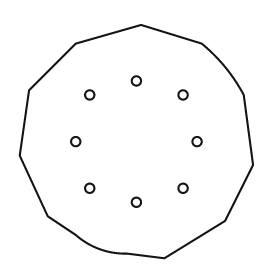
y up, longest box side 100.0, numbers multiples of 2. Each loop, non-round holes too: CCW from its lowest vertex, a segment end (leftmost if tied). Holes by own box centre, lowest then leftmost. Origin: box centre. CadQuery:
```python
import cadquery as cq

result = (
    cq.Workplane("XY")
    .moveTo(12.0, -50.0)
    .lineTo(38.0, -34.0)
    .lineTo(50.0, -10.0)
    .lineTo(46.0, 20.0)
    .threePointArc((38.0, 32.0), (28.0, 42.0))
    .lineTo(2.0, 50.0)
    .lineTo(-26.0, 42.0)
    .lineTo(-46.0, 22.0)
    .lineTo(-50.0, -6.0)
    .lineTo(-38.0, -32.0)
    .lineTo(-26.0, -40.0)
    .threePointArc((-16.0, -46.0), (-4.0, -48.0))
    .close()
    .moveTo(0.0, -26.0)
    .circle(2.0)
    .moveTo(-20.0, -20.0)
    .circle(2.0)
    .moveTo(20.0, -20.0)
    .circle(2.0)
    .moveTo(-26.0, 0.0)
    .circle(2.0)
    .moveTo(26.0, 0.0)
    .circle(2.0)
    .moveTo(-20.0, 20.0)
    .circle(2.0)
    .moveTo(20.0, 20.0)
    .circle(2.0)
    .moveTo(0.0, 26.0)
    .circle(2.0)
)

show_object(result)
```